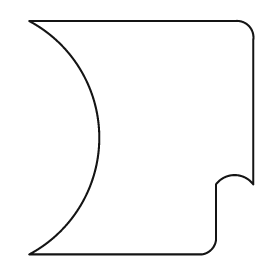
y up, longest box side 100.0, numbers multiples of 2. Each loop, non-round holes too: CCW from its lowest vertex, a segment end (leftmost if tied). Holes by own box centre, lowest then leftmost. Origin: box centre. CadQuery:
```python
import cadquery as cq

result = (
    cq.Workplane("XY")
    .moveTo(-48.0, -50.0)
    .lineTo(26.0, -50.0)
    .threePointArc((30.0, -48.0), (32.0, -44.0))
    .lineTo(32.0, -20.0)
    .threePointArc((40.0, -16.0), (48.0, -20.0))
    .lineTo(48.0, 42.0)
    .threePointArc((46.0, 48.0), (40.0, 50.0))
    .lineTo(-48.0, 50.0)
    .threePointArc((-18.0, 0.0), (-48.0, -50.0))
    .close()
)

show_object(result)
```